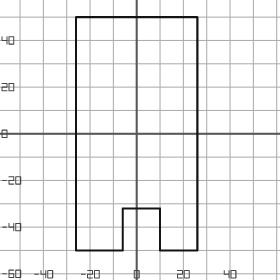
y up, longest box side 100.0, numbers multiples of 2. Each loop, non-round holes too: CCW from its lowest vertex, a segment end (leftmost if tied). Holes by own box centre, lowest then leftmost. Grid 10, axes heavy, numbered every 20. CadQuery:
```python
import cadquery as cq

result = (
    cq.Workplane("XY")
    .moveTo(-26.0, -50.0)
    .lineTo(-6.0, -50.0)
    .lineTo(-6.0, -32.0)
    .lineTo(10.0, -32.0)
    .lineTo(10.0, -50.0)
    .lineTo(26.0, -50.0)
    .lineTo(26.0, 50.0)
    .lineTo(-26.0, 50.0)
    .close()
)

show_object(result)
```